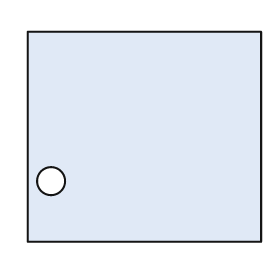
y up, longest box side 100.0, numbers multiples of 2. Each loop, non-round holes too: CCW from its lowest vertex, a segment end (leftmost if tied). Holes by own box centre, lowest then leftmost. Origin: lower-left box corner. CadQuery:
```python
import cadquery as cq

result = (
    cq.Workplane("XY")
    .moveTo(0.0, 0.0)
    .lineTo(100.0, 0.0)
    .lineTo(100.0, 90.0)
    .lineTo(0.0, 90.0)
    .close()
    .moveTo(10.0, 26.0)
    .circle(6.0)
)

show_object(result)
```